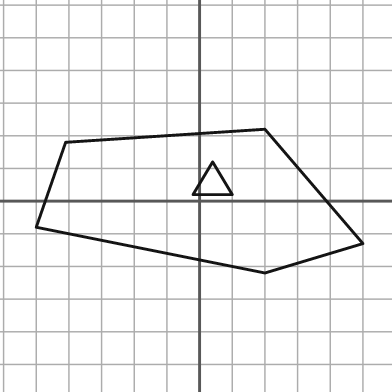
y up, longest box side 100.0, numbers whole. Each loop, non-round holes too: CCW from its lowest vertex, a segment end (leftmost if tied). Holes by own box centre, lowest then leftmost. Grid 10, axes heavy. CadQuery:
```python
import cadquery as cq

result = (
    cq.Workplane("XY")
    .moveTo(20.0, -22.0)
    .lineTo(50.0, -13.0)
    .lineTo(20.0, 22.0)
    .lineTo(-41.0, 18.0)
    .lineTo(-50.0, -8.0)
    .close()
    .moveTo(-2.0, 2.0)
    .lineTo(10.0, 2.0)
    .lineTo(4.0, 12.0)
    .close()
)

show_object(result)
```